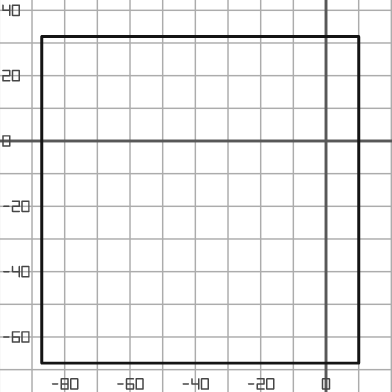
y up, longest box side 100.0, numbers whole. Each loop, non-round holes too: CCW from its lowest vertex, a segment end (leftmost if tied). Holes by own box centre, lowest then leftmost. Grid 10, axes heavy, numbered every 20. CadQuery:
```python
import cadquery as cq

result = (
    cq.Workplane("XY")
    .moveTo(-87.0, -68.0)
    .lineTo(10.0, -68.0)
    .lineTo(10.0, 32.0)
    .lineTo(-87.0, 32.0)
    .close()
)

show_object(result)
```